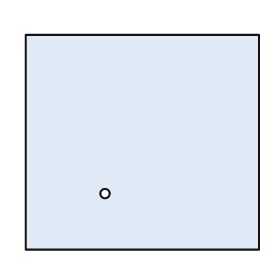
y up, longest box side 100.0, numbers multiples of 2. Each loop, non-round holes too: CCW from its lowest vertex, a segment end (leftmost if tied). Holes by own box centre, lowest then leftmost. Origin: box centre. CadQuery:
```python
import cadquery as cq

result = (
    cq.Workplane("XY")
    .moveTo(-50.0, -46.0)
    .lineTo(50.0, -46.0)
    .lineTo(50.0, 46.0)
    .lineTo(-50.0, 46.0)
    .close()
    .moveTo(-16.0, -22.0)
    .circle(2.0)
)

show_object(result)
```